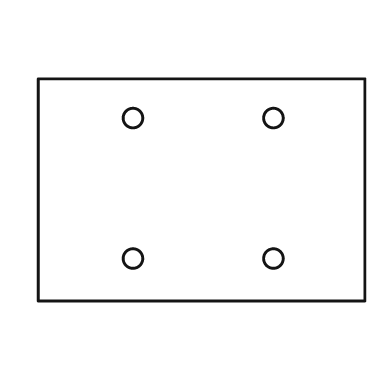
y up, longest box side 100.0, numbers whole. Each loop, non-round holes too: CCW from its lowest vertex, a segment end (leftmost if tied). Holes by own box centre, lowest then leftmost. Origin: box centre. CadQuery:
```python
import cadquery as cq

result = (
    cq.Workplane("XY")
    .moveTo(-50.0, -34.0)
    .lineTo(50.0, -34.0)
    .lineTo(50.0, 34.0)
    .lineTo(-50.0, 34.0)
    .close()
    .moveTo(-21.0, -21.0)
    .circle(3.0)
    .moveTo(22.0, -21.0)
    .circle(3.0)
    .moveTo(-21.0, 22.0)
    .circle(3.0)
    .moveTo(22.0, 22.0)
    .circle(3.0)
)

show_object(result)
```